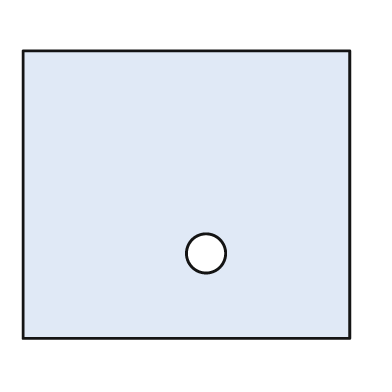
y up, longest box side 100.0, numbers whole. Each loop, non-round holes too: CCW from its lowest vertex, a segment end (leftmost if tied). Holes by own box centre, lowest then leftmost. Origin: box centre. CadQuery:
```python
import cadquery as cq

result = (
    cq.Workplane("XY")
    .moveTo(-50.0, -44.0)
    .lineTo(50.0, -44.0)
    .lineTo(50.0, 44.0)
    .lineTo(-50.0, 44.0)
    .close()
    .moveTo(6.0, -18.0)
    .circle(6.0)
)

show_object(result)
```